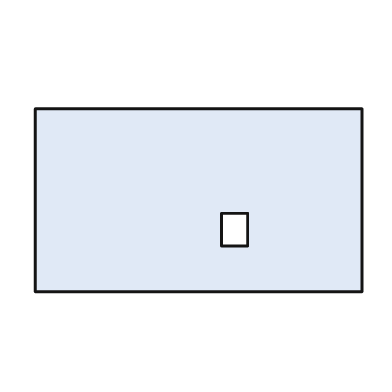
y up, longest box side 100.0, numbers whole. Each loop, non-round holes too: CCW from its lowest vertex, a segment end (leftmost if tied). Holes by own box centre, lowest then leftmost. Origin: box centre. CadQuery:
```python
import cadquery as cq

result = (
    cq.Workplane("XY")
    .moveTo(-50.0, -28.0)
    .lineTo(50.0, -28.0)
    .lineTo(50.0, 28.0)
    .lineTo(-50.0, 28.0)
    .close()
    .moveTo(7.0, -14.0)
    .lineTo(15.0, -14.0)
    .lineTo(15.0, -4.0)
    .lineTo(7.0, -4.0)
    .close()
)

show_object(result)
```